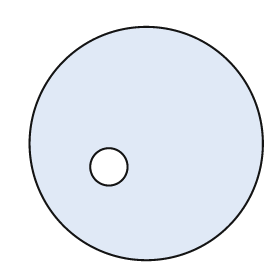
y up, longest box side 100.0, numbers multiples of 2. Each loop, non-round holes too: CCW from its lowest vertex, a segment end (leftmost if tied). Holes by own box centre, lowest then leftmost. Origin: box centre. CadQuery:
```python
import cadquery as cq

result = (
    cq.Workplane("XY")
    .moveTo(0.0, 0.0)
    .circle(50.0)
    .moveTo(-16.0, -10.0)
    .circle(8.0)
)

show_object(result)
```